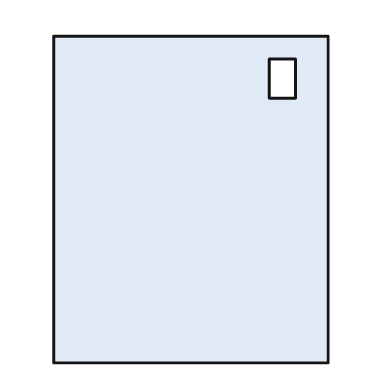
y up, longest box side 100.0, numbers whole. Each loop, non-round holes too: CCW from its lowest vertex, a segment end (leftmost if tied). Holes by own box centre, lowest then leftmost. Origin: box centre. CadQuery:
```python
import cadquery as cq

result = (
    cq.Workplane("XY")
    .moveTo(-42.0, -50.0)
    .lineTo(42.0, -50.0)
    .lineTo(42.0, 50.0)
    .lineTo(-42.0, 50.0)
    .close()
    .moveTo(24.0, 31.0)
    .lineTo(32.0, 31.0)
    .lineTo(32.0, 43.0)
    .lineTo(24.0, 43.0)
    .close()
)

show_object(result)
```